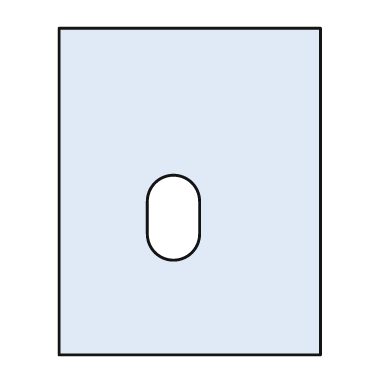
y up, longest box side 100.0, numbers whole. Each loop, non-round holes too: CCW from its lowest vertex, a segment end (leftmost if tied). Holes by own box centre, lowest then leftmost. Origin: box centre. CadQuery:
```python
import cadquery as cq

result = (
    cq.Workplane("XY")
    .moveTo(-40.0, -50.0)
    .lineTo(40.0, -50.0)
    .lineTo(40.0, 50.0)
    .lineTo(-40.0, 50.0)
    .close()
    .moveTo(-13.0, -13.0)
    .threePointArc((-5.0, -21.0), (3.0, -13.0))
    .lineTo(3.0, -3.0)
    .threePointArc((-5.0, 5.0), (-13.0, -3.0))
    .close()
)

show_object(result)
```